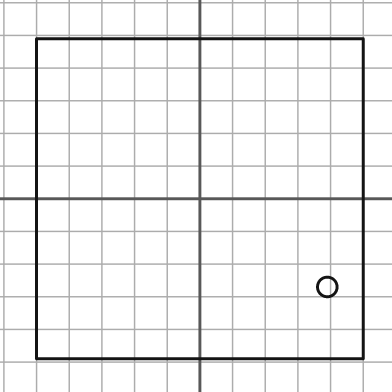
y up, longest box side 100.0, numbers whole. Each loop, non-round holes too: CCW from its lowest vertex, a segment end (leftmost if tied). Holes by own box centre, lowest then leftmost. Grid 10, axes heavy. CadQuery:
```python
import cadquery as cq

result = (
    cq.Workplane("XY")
    .moveTo(-50.0, -49.0)
    .lineTo(50.0, -49.0)
    .lineTo(50.0, 49.0)
    .lineTo(-50.0, 49.0)
    .close()
    .moveTo(39.0, -27.0)
    .circle(3.0)
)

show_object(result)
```